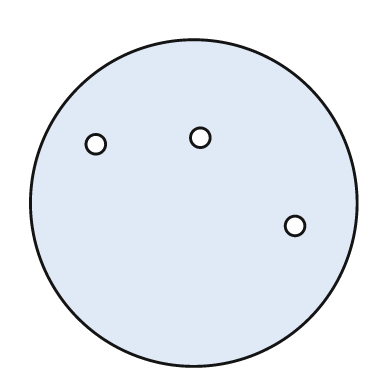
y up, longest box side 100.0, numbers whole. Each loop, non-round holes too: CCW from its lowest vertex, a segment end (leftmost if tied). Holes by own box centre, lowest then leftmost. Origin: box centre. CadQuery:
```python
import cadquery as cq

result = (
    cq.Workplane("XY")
    .moveTo(0.0, 0.0)
    .circle(50.0)
    .moveTo(31.0, -7.0)
    .circle(3.0)
    .moveTo(-30.0, 18.0)
    .circle(3.0)
    .moveTo(2.0, 20.0)
    .circle(3.0)
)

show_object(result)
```